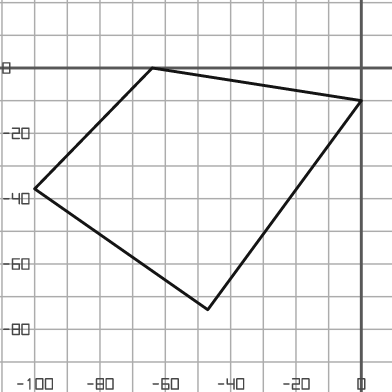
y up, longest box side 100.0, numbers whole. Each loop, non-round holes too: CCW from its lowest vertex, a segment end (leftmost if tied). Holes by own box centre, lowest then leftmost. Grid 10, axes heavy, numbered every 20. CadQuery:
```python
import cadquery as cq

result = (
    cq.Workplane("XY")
    .moveTo(-47.0, -74.0)
    .lineTo(0.0, -10.0)
    .lineTo(-64.0, 0.0)
    .lineTo(-100.0, -37.0)
    .close()
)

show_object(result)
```